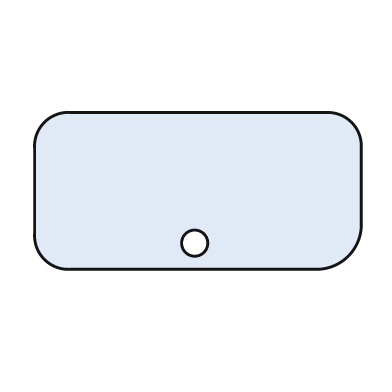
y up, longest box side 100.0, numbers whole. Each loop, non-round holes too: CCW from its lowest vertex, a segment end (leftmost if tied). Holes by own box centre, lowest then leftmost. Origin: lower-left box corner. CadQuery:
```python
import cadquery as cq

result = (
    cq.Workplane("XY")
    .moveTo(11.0, 0.0)
    .lineTo(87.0, 0.0)
    .threePointArc((96.0, 4.0), (100.0, 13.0))
    .lineTo(100.0, 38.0)
    .threePointArc((97.0, 45.0), (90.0, 48.0))
    .lineTo(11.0, 48.0)
    .threePointArc((3.0, 45.0), (0.0, 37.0))
    .lineTo(0.0, 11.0)
    .threePointArc((3.0, 3.0), (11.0, 0.0))
    .close()
    .moveTo(49.0, 8.0)
    .circle(4.0)
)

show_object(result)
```